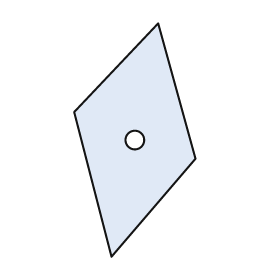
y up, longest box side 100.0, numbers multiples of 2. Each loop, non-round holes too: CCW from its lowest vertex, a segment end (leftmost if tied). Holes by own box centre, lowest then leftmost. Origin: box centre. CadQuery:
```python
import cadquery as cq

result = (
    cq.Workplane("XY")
    .moveTo(-10.0, -50.0)
    .lineTo(26.0, -8.0)
    .lineTo(10.0, 50.0)
    .lineTo(-26.0, 12.0)
    .close()
    .moveTo(0.0, 0.0)
    .circle(4.0)
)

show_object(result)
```